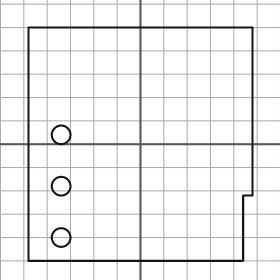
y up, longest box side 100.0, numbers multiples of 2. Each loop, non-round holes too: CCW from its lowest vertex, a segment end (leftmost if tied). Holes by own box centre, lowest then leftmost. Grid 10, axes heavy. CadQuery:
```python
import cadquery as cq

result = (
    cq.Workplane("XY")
    .moveTo(-48.0, -50.0)
    .lineTo(44.0, -50.0)
    .lineTo(44.0, -22.0)
    .lineTo(48.0, -22.0)
    .lineTo(48.0, 50.0)
    .lineTo(-48.0, 50.0)
    .close()
    .moveTo(-34.0, -40.0)
    .circle(4.0)
    .moveTo(-34.0, -18.0)
    .circle(4.0)
    .moveTo(-34.0, 4.0)
    .circle(4.0)
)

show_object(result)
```